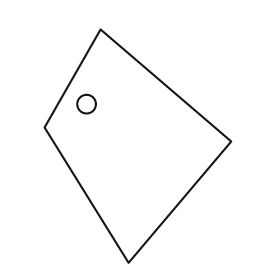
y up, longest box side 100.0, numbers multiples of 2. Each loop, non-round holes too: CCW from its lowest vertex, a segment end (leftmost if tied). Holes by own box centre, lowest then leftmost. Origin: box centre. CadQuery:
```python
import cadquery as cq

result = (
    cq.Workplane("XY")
    .moveTo(-4.0, -50.0)
    .lineTo(40.0, 2.0)
    .lineTo(-16.0, 50.0)
    .lineTo(-40.0, 8.0)
    .close()
    .moveTo(-22.0, 18.0)
    .circle(4.0)
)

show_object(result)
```